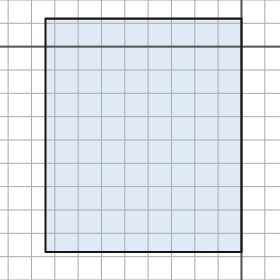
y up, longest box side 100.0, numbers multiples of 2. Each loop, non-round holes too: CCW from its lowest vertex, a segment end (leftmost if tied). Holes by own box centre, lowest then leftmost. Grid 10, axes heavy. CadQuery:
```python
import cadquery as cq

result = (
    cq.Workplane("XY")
    .moveTo(-84.0, -88.0)
    .lineTo(0.0, -88.0)
    .lineTo(0.0, 12.0)
    .lineTo(-84.0, 12.0)
    .close()
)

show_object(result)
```